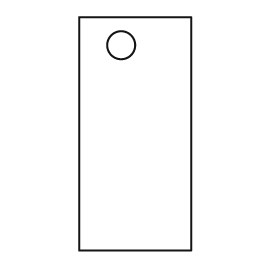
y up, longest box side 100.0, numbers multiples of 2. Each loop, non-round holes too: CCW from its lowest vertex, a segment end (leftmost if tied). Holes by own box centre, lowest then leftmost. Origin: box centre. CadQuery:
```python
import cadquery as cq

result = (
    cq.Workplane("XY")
    .moveTo(-24.0, -50.0)
    .lineTo(24.0, -50.0)
    .lineTo(24.0, 50.0)
    .lineTo(-24.0, 50.0)
    .close()
    .moveTo(-6.0, 38.0)
    .circle(6.0)
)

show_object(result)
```